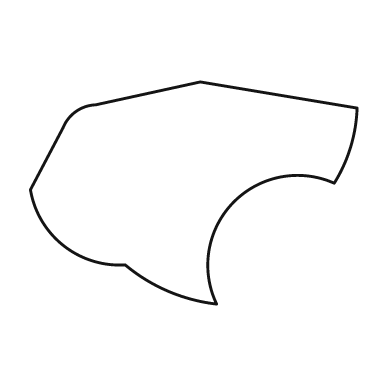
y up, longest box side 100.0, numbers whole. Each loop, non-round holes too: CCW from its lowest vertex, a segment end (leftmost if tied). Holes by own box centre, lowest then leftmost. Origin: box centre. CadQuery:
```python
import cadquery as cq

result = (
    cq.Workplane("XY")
    .moveTo(7.0, -34.0)
    .threePointArc((12.0, -3.0), (43.0, 3.0))
    .threePointArc((48.0, 14.0), (50.0, 26.0))
    .lineTo(2.0, 34.0)
    .lineTo(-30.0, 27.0)
    .threePointArc((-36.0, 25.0), (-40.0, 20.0))
    .lineTo(-50.0, 1.0)
    .threePointArc((-40.0, -16.0), (-21.0, -22.0))
    .threePointArc((-8.0, -30.0), (7.0, -34.0))
    .close()
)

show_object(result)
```